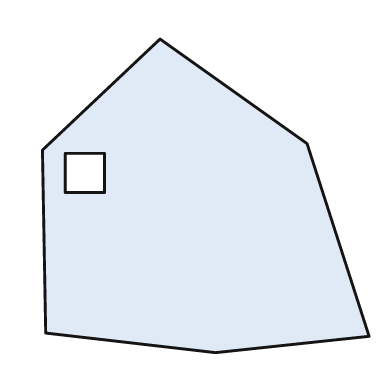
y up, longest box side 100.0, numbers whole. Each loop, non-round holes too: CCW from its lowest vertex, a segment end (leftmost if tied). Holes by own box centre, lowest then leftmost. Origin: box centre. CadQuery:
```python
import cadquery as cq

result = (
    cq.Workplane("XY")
    .moveTo(3.0, -48.0)
    .lineTo(50.0, -43.0)
    .lineTo(31.0, 16.0)
    .lineTo(-14.0, 48.0)
    .lineTo(-50.0, 14.0)
    .lineTo(-49.0, -42.0)
    .close()
    .moveTo(-43.0, 1.0)
    .lineTo(-31.0, 1.0)
    .lineTo(-31.0, 13.0)
    .lineTo(-43.0, 13.0)
    .close()
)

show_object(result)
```